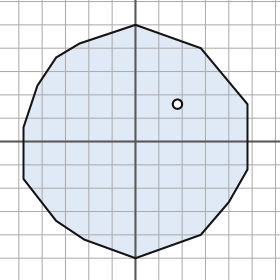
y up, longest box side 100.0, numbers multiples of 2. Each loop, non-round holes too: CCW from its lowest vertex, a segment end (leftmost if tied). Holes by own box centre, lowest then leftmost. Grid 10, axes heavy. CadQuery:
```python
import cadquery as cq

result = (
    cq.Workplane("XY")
    .moveTo(0.0, -50.0)
    .lineTo(28.0, -40.0)
    .lineTo(40.0, -26.0)
    .lineTo(48.0, -12.0)
    .lineTo(48.0, 16.0)
    .lineTo(28.0, 40.0)
    .lineTo(0.0, 50.0)
    .lineTo(-24.0, 42.0)
    .lineTo(-34.0, 36.0)
    .lineTo(-42.0, 24.0)
    .lineTo(-48.0, 6.0)
    .lineTo(-48.0, -16.0)
    .lineTo(-34.0, -34.0)
    .lineTo(-22.0, -42.0)
    .close()
    .moveTo(18.0, 16.0)
    .circle(2.0)
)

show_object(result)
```